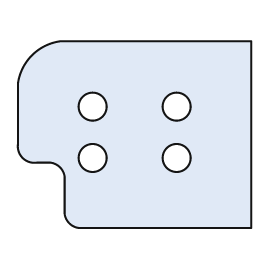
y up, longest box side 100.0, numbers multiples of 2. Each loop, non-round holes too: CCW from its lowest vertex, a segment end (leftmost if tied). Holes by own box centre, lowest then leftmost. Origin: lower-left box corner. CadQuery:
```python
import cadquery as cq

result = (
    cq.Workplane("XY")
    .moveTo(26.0, 0.0)
    .lineTo(100.0, 0.0)
    .lineTo(100.0, 80.0)
    .lineTo(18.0, 80.0)
    .threePointArc((6.0, 74.0), (0.0, 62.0))
    .lineTo(0.0, 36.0)
    .threePointArc((2.0, 30.0), (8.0, 28.0))
    .lineTo(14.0, 28.0)
    .threePointArc((18.0, 26.0), (20.0, 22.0))
    .lineTo(20.0, 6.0)
    .threePointArc((22.0, 2.0), (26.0, 0.0))
    .close()
    .moveTo(32.0, 30.0)
    .circle(6.0)
    .moveTo(68.0, 30.0)
    .circle(6.0)
    .moveTo(32.0, 52.0)
    .circle(6.0)
    .moveTo(68.0, 52.0)
    .circle(6.0)
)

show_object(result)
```